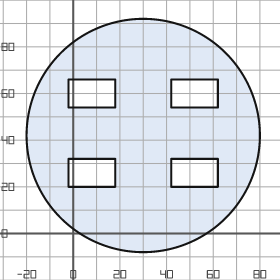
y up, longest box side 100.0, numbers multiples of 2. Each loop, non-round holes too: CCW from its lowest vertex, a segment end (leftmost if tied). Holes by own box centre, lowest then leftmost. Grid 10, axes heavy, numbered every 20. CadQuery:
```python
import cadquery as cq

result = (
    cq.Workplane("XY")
    .moveTo(30.0, 42.0)
    .circle(50.0)
    .moveTo(-2.0, 20.0)
    .lineTo(18.0, 20.0)
    .lineTo(18.0, 32.0)
    .lineTo(-2.0, 32.0)
    .close()
    .moveTo(42.0, 20.0)
    .lineTo(62.0, 20.0)
    .lineTo(62.0, 32.0)
    .lineTo(42.0, 32.0)
    .close()
    .moveTo(-2.0, 54.0)
    .lineTo(18.0, 54.0)
    .lineTo(18.0, 66.0)
    .lineTo(-2.0, 66.0)
    .close()
    .moveTo(42.0, 54.0)
    .lineTo(62.0, 54.0)
    .lineTo(62.0, 66.0)
    .lineTo(42.0, 66.0)
    .close()
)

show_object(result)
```